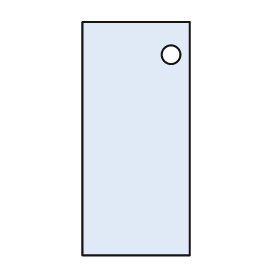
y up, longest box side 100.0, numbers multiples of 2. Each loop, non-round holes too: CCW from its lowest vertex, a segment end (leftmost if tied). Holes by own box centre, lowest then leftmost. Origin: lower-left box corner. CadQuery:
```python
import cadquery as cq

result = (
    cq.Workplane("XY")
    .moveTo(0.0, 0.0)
    .lineTo(46.0, 0.0)
    .lineTo(46.0, 100.0)
    .lineTo(0.0, 100.0)
    .close()
    .moveTo(38.0, 86.0)
    .circle(4.0)
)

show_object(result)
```